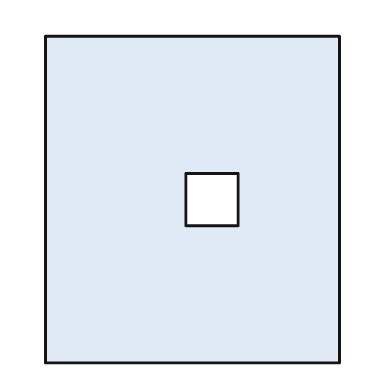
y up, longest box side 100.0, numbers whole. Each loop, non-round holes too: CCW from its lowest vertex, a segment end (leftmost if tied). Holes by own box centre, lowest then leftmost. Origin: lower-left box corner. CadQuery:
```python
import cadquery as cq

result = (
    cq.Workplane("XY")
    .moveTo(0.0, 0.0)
    .lineTo(90.0, 0.0)
    .lineTo(90.0, 100.0)
    .lineTo(0.0, 100.0)
    .close()
    .moveTo(43.0, 42.0)
    .lineTo(59.0, 42.0)
    .lineTo(59.0, 58.0)
    .lineTo(43.0, 58.0)
    .close()
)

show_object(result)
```